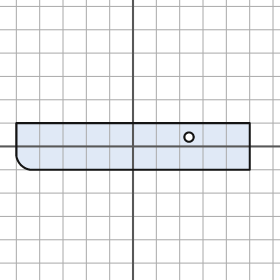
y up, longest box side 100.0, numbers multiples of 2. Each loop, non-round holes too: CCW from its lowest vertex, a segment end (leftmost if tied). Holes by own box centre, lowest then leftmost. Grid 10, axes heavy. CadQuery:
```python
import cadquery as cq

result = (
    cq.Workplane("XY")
    .moveTo(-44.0, -10.0)
    .lineTo(50.0, -10.0)
    .lineTo(50.0, 10.0)
    .lineTo(-50.0, 10.0)
    .lineTo(-50.0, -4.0)
    .threePointArc((-48.0, -8.0), (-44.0, -10.0))
    .close()
    .moveTo(24.0, 4.0)
    .circle(2.0)
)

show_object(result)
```